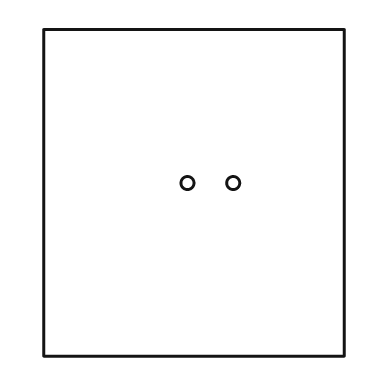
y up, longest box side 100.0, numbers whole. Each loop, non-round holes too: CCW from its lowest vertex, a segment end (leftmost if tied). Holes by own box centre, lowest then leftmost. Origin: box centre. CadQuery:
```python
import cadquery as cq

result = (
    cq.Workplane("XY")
    .moveTo(-46.0, -50.0)
    .lineTo(46.0, -50.0)
    .lineTo(46.0, 50.0)
    .lineTo(-46.0, 50.0)
    .close()
    .moveTo(-2.0, 3.0)
    .circle(2.0)
    .moveTo(12.0, 3.0)
    .circle(2.0)
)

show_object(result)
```